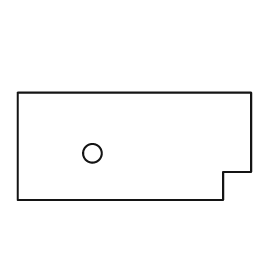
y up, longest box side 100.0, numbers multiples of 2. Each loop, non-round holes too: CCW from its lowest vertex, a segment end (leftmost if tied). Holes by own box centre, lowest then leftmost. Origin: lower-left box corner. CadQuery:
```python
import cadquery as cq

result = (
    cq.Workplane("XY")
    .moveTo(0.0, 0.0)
    .lineTo(88.0, 0.0)
    .lineTo(88.0, 12.0)
    .lineTo(100.0, 12.0)
    .lineTo(100.0, 46.0)
    .lineTo(0.0, 46.0)
    .close()
    .moveTo(32.0, 20.0)
    .circle(4.0)
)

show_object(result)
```